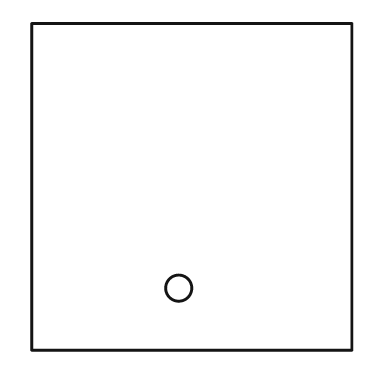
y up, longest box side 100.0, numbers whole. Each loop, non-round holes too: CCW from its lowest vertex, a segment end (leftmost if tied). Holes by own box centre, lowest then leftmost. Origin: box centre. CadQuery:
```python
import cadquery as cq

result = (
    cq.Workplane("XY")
    .moveTo(-49.0, -50.0)
    .lineTo(49.0, -50.0)
    .lineTo(49.0, 50.0)
    .lineTo(-49.0, 50.0)
    .close()
    .moveTo(-4.0, -31.0)
    .circle(4.0)
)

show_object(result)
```